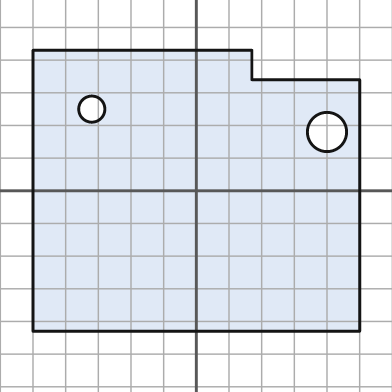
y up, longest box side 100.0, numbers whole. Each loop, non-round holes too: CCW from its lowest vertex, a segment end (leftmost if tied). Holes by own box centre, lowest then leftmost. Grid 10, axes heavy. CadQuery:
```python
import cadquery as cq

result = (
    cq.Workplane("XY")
    .moveTo(-50.0, -43.0)
    .lineTo(50.0, -43.0)
    .lineTo(50.0, 34.0)
    .lineTo(17.0, 34.0)
    .lineTo(17.0, 43.0)
    .lineTo(-50.0, 43.0)
    .close()
    .moveTo(40.0, 18.0)
    .circle(6.0)
    .moveTo(-32.0, 25.0)
    .circle(4.0)
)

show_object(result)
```